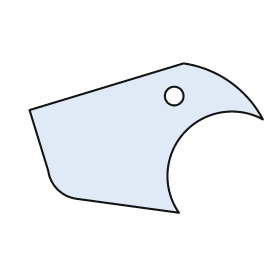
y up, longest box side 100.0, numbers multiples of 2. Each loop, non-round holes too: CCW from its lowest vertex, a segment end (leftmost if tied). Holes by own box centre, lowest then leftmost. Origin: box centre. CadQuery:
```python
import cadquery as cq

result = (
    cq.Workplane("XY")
    .moveTo(14.0, -32.0)
    .threePointArc((16.0, 2.0), (50.0, 8.0))
    .threePointArc((36.0, 24.0), (16.0, 32.0))
    .lineTo(-50.0, 12.0)
    .lineTo(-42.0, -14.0)
    .threePointArc((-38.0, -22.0), (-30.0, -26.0))
    .close()
    .moveTo(12.0, 18.0)
    .circle(4.0)
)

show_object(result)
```